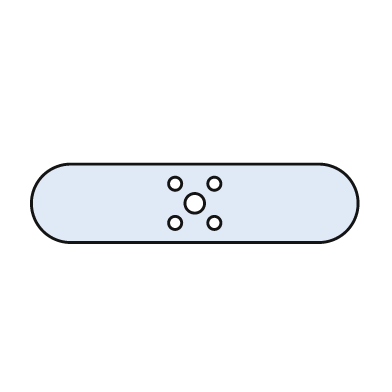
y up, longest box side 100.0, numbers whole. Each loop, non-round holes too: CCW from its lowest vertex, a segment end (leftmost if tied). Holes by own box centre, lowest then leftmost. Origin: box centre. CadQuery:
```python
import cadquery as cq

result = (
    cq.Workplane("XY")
    .moveTo(-38.0, -12.0)
    .lineTo(38.0, -12.0)
    .threePointArc((50.0, 0.0), (38.0, 12.0))
    .lineTo(-38.0, 12.0)
    .threePointArc((-50.0, 0.0), (-38.0, -12.0))
    .close()
    .moveTo(-6.0, -6.0)
    .circle(2.0)
    .moveTo(6.0, -6.0)
    .circle(2.0)
    .moveTo(0.0, 0.0)
    .circle(3.0)
    .moveTo(-6.0, 6.0)
    .circle(2.0)
    .moveTo(6.0, 6.0)
    .circle(2.0)
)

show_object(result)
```